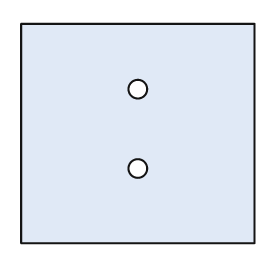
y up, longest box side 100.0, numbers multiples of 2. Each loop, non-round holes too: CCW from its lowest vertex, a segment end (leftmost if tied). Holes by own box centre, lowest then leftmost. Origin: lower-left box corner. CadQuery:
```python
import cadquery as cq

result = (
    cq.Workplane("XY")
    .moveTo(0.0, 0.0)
    .lineTo(100.0, 0.0)
    .lineTo(100.0, 94.0)
    .lineTo(0.0, 94.0)
    .close()
    .moveTo(50.0, 32.0)
    .circle(4.0)
    .moveTo(50.0, 66.0)
    .circle(4.0)
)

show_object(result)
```